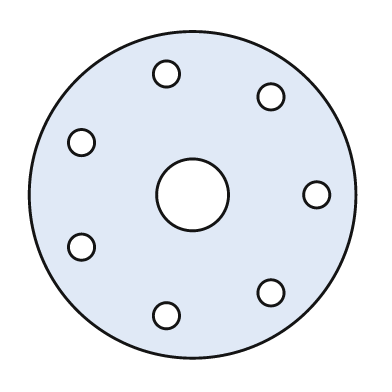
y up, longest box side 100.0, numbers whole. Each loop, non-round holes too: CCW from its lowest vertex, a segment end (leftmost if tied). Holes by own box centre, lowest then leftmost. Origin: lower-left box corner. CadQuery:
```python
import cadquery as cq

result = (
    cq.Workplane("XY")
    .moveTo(50.0, 50.0)
    .circle(50.0)
    .moveTo(42.0, 13.0)
    .circle(4.0)
    .moveTo(74.0, 20.0)
    .circle(4.0)
    .moveTo(16.0, 34.0)
    .circle(4.0)
    .moveTo(50.0, 50.0)
    .circle(11.0)
    .moveTo(88.0, 50.0)
    .circle(4.0)
    .moveTo(16.0, 66.0)
    .circle(4.0)
    .moveTo(74.0, 80.0)
    .circle(4.0)
    .moveTo(42.0, 87.0)
    .circle(4.0)
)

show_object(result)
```